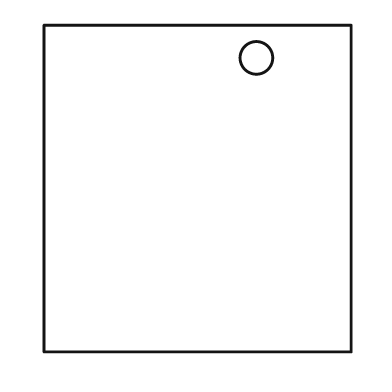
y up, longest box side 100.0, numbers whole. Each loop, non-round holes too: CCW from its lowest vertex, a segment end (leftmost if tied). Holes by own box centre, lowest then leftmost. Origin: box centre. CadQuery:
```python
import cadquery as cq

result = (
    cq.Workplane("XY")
    .moveTo(-47.0, -50.0)
    .lineTo(47.0, -50.0)
    .lineTo(47.0, 50.0)
    .lineTo(-47.0, 50.0)
    .close()
    .moveTo(18.0, 40.0)
    .circle(5.0)
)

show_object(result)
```